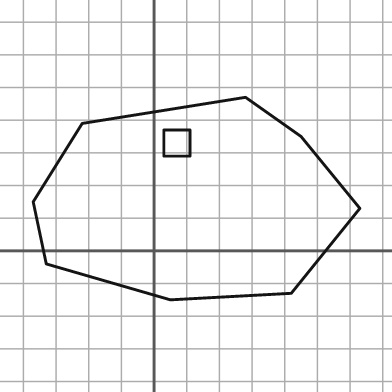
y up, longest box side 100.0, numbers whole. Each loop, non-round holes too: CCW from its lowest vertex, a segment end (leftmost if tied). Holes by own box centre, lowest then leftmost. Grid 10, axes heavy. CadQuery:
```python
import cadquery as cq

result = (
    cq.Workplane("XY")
    .moveTo(5.0, -15.0)
    .lineTo(42.0, -13.0)
    .lineTo(63.0, 13.0)
    .lineTo(45.0, 35.0)
    .lineTo(28.0, 47.0)
    .lineTo(-22.0, 39.0)
    .lineTo(-37.0, 15.0)
    .lineTo(-33.0, -4.0)
    .close()
    .moveTo(3.0, 29.0)
    .lineTo(11.0, 29.0)
    .lineTo(11.0, 37.0)
    .lineTo(3.0, 37.0)
    .close()
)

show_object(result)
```